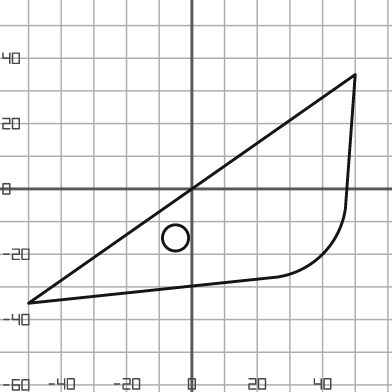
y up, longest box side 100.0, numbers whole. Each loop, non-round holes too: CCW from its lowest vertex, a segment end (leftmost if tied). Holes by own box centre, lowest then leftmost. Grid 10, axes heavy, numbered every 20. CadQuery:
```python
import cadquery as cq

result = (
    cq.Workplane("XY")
    .moveTo(-50.0, -35.0)
    .lineTo(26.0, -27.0)
    .threePointArc((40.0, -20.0), (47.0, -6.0))
    .lineTo(50.0, 35.0)
    .close()
    .moveTo(-5.0, -15.0)
    .circle(4.0)
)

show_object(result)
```